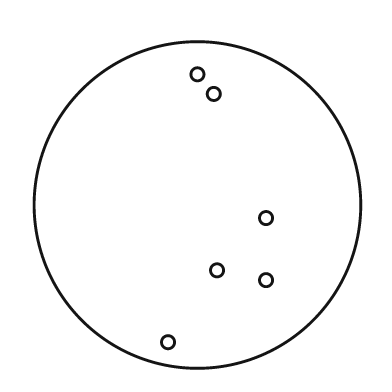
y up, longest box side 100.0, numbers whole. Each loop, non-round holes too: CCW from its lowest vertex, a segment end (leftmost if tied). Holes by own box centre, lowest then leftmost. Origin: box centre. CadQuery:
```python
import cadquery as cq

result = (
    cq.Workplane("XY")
    .moveTo(0.0, 0.0)
    .circle(50.0)
    .moveTo(-9.0, -42.0)
    .circle(2.0)
    .moveTo(21.0, -23.0)
    .circle(2.0)
    .moveTo(6.0, -20.0)
    .circle(2.0)
    .moveTo(21.0, -4.0)
    .circle(2.0)
    .moveTo(5.0, 34.0)
    .circle(2.0)
    .moveTo(0.0, 40.0)
    .circle(2.0)
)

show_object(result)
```